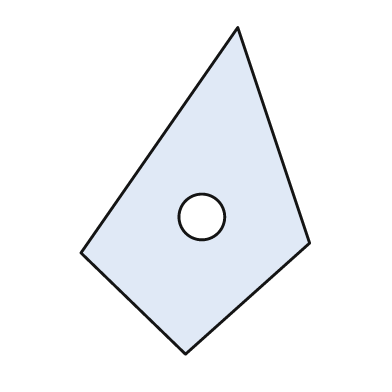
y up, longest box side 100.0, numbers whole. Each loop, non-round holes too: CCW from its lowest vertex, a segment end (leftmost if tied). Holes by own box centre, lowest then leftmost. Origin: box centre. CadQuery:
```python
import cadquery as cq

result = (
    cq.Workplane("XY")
    .moveTo(-3.0, -50.0)
    .lineTo(35.0, -16.0)
    .lineTo(13.0, 50.0)
    .lineTo(-35.0, -19.0)
    .close()
    .moveTo(2.0, -8.0)
    .circle(7.0)
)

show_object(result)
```